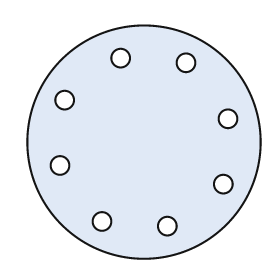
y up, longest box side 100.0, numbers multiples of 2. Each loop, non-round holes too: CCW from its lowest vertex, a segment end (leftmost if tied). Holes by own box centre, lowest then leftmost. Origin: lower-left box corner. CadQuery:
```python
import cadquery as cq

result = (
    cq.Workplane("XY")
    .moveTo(50.0, 50.0)
    .circle(50.0)
    .moveTo(60.0, 14.0)
    .circle(4.0)
    .moveTo(32.0, 16.0)
    .circle(4.0)
    .moveTo(84.0, 32.0)
    .circle(4.0)
    .moveTo(14.0, 40.0)
    .circle(4.0)
    .moveTo(86.0, 60.0)
    .circle(4.0)
    .moveTo(16.0, 68.0)
    .circle(4.0)
    .moveTo(68.0, 84.0)
    .circle(4.0)
    .moveTo(40.0, 86.0)
    .circle(4.0)
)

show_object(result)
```